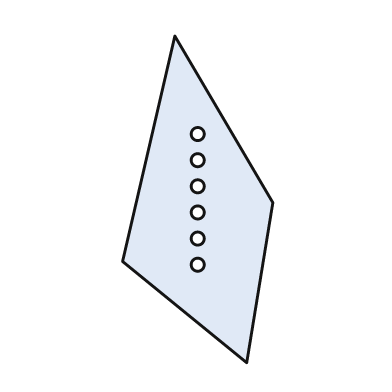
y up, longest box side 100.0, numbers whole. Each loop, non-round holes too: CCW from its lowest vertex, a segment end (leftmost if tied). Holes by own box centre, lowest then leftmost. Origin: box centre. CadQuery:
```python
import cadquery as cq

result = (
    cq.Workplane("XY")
    .moveTo(15.0, -50.0)
    .lineTo(23.0, -1.0)
    .lineTo(-7.0, 50.0)
    .lineTo(-23.0, -19.0)
    .close()
    .moveTo(0.0, -20.0)
    .circle(2.0)
    .moveTo(0.0, -12.0)
    .circle(2.0)
    .moveTo(0.0, -4.0)
    .circle(2.0)
    .moveTo(0.0, 4.0)
    .circle(2.0)
    .moveTo(0.0, 12.0)
    .circle(2.0)
    .moveTo(0.0, 20.0)
    .circle(2.0)
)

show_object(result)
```